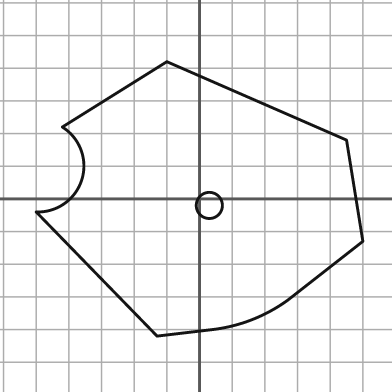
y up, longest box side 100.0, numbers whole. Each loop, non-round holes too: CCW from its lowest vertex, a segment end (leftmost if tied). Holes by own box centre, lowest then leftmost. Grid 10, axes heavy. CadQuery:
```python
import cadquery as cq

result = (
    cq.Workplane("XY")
    .moveTo(-13.0, -42.0)
    .lineTo(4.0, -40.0)
    .threePointArc((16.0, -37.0), (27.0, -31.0))
    .lineTo(50.0, -13.0)
    .lineTo(45.0, 18.0)
    .lineTo(-10.0, 42.0)
    .lineTo(-42.0, 22.0)
    .threePointArc((-36.0, 6.0), (-50.0, -4.0))
    .close()
    .moveTo(3.0, -2.0)
    .circle(4.0)
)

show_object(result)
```